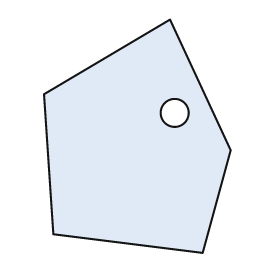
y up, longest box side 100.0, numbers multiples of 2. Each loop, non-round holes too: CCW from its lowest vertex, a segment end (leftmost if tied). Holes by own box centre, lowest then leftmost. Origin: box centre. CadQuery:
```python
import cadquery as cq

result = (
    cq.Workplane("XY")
    .moveTo(28.0, -50.0)
    .lineTo(40.0, -6.0)
    .lineTo(14.0, 50.0)
    .lineTo(-40.0, 18.0)
    .lineTo(-36.0, -42.0)
    .close()
    .moveTo(16.0, 10.0)
    .circle(6.0)
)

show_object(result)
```